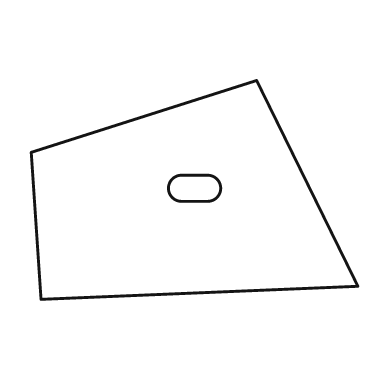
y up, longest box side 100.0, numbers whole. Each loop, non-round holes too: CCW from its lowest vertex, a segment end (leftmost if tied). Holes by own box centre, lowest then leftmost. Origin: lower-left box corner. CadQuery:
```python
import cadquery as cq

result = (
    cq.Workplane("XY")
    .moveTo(3.0, 0.0)
    .lineTo(100.0, 4.0)
    .lineTo(69.0, 67.0)
    .lineTo(0.0, 45.0)
    .close()
    .moveTo(46.0, 30.0)
    .lineTo(54.0, 30.0)
    .threePointArc((58.0, 34.0), (54.0, 38.0))
    .lineTo(46.0, 38.0)
    .threePointArc((42.0, 34.0), (46.0, 30.0))
    .close()
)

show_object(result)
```